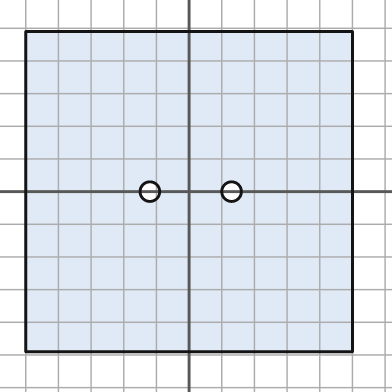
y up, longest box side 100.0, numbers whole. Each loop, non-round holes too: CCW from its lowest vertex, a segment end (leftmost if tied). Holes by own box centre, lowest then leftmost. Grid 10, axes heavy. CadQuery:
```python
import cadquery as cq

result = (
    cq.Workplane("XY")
    .moveTo(-50.0, -49.0)
    .lineTo(50.0, -49.0)
    .lineTo(50.0, 49.0)
    .lineTo(-50.0, 49.0)
    .close()
    .moveTo(-12.0, 0.0)
    .circle(3.0)
    .moveTo(13.0, 0.0)
    .circle(3.0)
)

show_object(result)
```